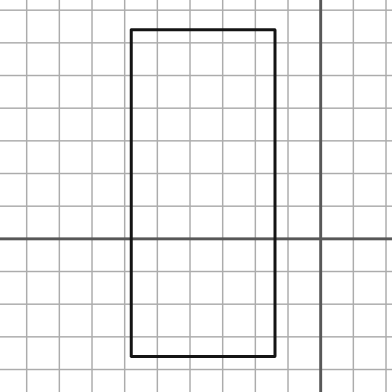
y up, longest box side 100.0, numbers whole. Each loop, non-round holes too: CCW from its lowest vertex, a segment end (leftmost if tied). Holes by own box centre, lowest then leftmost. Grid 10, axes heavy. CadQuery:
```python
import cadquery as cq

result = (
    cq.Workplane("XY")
    .moveTo(-58.0, -36.0)
    .lineTo(-14.0, -36.0)
    .lineTo(-14.0, 64.0)
    .lineTo(-58.0, 64.0)
    .close()
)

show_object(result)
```